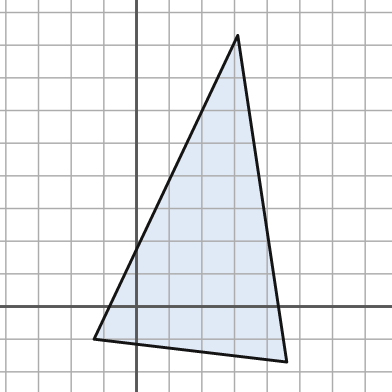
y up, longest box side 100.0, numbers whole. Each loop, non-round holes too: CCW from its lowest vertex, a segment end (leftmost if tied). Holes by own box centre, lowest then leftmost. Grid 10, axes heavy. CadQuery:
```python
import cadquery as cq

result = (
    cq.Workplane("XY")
    .moveTo(46.0, -17.0)
    .lineTo(31.0, 83.0)
    .lineTo(-13.0, -10.0)
    .close()
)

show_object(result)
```